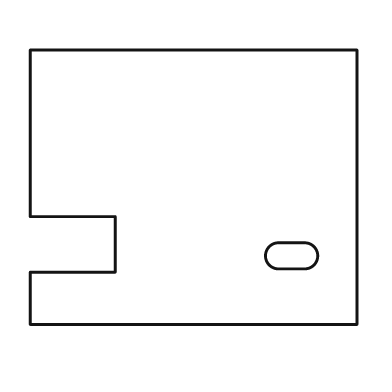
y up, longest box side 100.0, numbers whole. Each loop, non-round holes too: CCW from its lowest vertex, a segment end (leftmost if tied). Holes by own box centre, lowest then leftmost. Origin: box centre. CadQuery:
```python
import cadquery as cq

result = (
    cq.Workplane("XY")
    .moveTo(-50.0, -42.0)
    .lineTo(50.0, -42.0)
    .lineTo(50.0, 42.0)
    .lineTo(-50.0, 42.0)
    .lineTo(-50.0, -9.0)
    .lineTo(-24.0, -9.0)
    .lineTo(-24.0, -26.0)
    .lineTo(-50.0, -26.0)
    .close()
    .moveTo(26.0, -25.0)
    .lineTo(34.0, -25.0)
    .threePointArc((38.0, -21.0), (34.0, -17.0))
    .lineTo(26.0, -17.0)
    .threePointArc((22.0, -21.0), (26.0, -25.0))
    .close()
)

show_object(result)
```